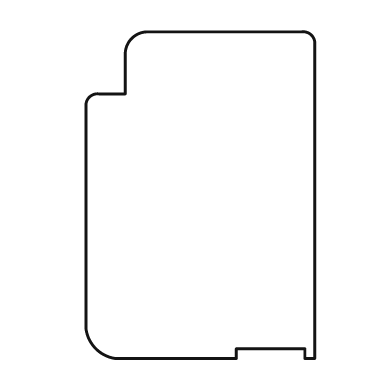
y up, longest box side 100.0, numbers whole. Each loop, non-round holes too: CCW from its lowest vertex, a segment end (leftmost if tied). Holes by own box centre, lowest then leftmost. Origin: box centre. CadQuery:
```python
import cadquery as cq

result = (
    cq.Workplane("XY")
    .moveTo(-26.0, -50.0)
    .lineTo(11.0, -50.0)
    .lineTo(11.0, -47.0)
    .lineTo(32.0, -47.0)
    .lineTo(32.0, -50.0)
    .lineTo(35.0, -50.0)
    .lineTo(35.0, 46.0)
    .threePointArc((34.0, 49.0), (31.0, 50.0))
    .lineTo(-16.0, 50.0)
    .threePointArc((-21.0, 48.0), (-23.0, 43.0))
    .lineTo(-23.0, 31.0)
    .lineTo(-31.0, 31.0)
    .threePointArc((-34.0, 30.0), (-35.0, 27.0))
    .lineTo(-35.0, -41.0)
    .threePointArc((-32.0, -47.0), (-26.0, -50.0))
    .close()
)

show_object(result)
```